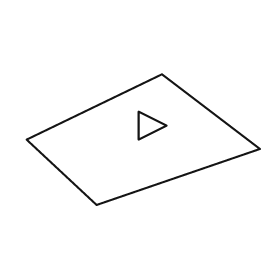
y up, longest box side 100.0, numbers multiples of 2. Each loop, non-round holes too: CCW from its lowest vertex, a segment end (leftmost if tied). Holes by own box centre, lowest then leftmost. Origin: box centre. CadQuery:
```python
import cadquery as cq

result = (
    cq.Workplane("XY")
    .moveTo(-20.0, -28.0)
    .lineTo(50.0, -4.0)
    .lineTo(8.0, 28.0)
    .lineTo(-50.0, 0.0)
    .close()
    .moveTo(-2.0, 0.0)
    .lineTo(10.0, 6.0)
    .lineTo(-2.0, 12.0)
    .close()
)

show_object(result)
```